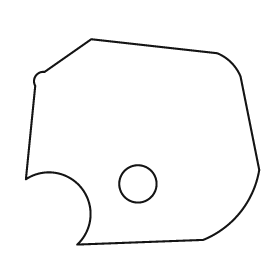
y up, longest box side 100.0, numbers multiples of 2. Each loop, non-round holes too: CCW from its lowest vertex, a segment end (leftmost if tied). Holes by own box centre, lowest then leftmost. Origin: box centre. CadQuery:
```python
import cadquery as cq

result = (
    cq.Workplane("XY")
    .moveTo(-28.0, -44.0)
    .lineTo(26.0, -42.0)
    .threePointArc((42.0, -30.0), (50.0, -12.0))
    .lineTo(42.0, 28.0)
    .threePointArc((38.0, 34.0), (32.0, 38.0))
    .lineTo(-22.0, 44.0)
    .lineTo(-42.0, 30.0)
    .threePointArc((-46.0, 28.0), (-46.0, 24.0))
    .lineTo(-50.0, -16.0)
    .threePointArc((-26.0, -20.0), (-28.0, -44.0))
    .close()
    .moveTo(-2.0, -18.0)
    .circle(8.0)
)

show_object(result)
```